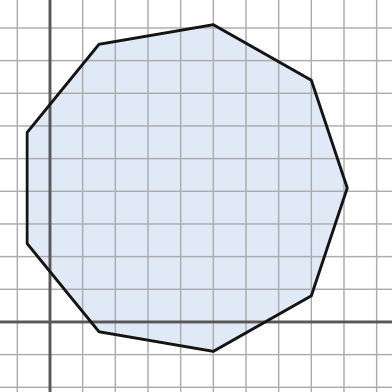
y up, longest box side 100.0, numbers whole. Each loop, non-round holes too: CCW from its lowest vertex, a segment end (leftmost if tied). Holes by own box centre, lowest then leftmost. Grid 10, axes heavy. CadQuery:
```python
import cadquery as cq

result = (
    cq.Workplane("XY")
    .moveTo(50.0, -9.0)
    .lineTo(80.0, 8.0)
    .lineTo(91.0, 41.0)
    .lineTo(80.0, 74.0)
    .lineTo(50.0, 91.0)
    .lineTo(15.0, 85.0)
    .lineTo(-7.0, 58.0)
    .lineTo(-7.0, 24.0)
    .lineTo(15.0, -3.0)
    .close()
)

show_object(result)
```